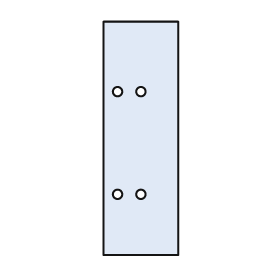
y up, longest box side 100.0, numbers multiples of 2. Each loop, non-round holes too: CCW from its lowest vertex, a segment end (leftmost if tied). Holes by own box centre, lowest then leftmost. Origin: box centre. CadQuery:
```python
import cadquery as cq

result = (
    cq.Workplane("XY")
    .moveTo(-16.0, -50.0)
    .lineTo(16.0, -50.0)
    .lineTo(16.0, 50.0)
    .lineTo(-16.0, 50.0)
    .close()
    .moveTo(-10.0, -24.0)
    .circle(2.0)
    .moveTo(0.0, -24.0)
    .circle(2.0)
    .moveTo(-10.0, 20.0)
    .circle(2.0)
    .moveTo(0.0, 20.0)
    .circle(2.0)
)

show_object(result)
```